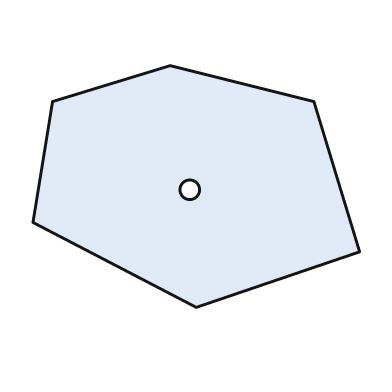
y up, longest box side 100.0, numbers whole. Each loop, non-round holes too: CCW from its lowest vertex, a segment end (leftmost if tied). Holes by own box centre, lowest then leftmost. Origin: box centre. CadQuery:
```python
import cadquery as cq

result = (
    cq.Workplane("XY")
    .moveTo(0.0, -37.0)
    .lineTo(50.0, -20.0)
    .lineTo(36.0, 26.0)
    .lineTo(-8.0, 37.0)
    .lineTo(-44.0, 26.0)
    .lineTo(-50.0, -11.0)
    .close()
    .moveTo(-2.0, -1.0)
    .circle(3.0)
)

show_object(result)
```